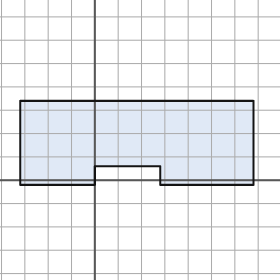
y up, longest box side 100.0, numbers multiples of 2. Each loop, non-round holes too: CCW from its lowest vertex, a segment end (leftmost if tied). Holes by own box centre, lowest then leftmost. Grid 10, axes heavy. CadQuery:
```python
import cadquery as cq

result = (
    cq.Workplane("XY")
    .moveTo(-32.0, -2.0)
    .lineTo(0.0, -2.0)
    .lineTo(0.0, 6.0)
    .lineTo(28.0, 6.0)
    .lineTo(28.0, -2.0)
    .lineTo(68.0, -2.0)
    .lineTo(68.0, 34.0)
    .lineTo(-32.0, 34.0)
    .close()
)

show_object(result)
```